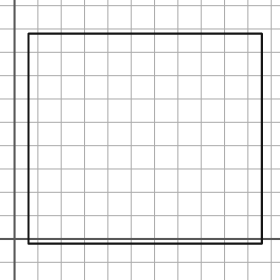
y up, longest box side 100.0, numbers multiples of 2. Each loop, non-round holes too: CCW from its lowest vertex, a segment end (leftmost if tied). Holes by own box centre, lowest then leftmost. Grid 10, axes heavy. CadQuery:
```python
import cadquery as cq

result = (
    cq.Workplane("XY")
    .moveTo(6.0, -2.0)
    .lineTo(106.0, -2.0)
    .lineTo(106.0, 88.0)
    .lineTo(6.0, 88.0)
    .close()
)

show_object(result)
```